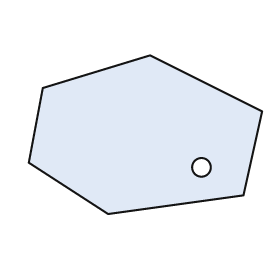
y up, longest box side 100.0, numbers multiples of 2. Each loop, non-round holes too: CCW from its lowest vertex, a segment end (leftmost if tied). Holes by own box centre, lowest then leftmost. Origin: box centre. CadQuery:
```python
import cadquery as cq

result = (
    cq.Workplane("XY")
    .moveTo(-16.0, -34.0)
    .lineTo(42.0, -26.0)
    .lineTo(50.0, 10.0)
    .lineTo(2.0, 34.0)
    .lineTo(-44.0, 20.0)
    .lineTo(-50.0, -12.0)
    .close()
    .moveTo(24.0, -14.0)
    .circle(4.0)
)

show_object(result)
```